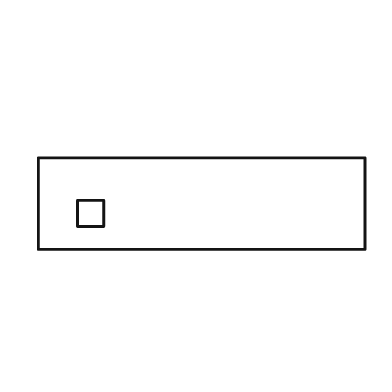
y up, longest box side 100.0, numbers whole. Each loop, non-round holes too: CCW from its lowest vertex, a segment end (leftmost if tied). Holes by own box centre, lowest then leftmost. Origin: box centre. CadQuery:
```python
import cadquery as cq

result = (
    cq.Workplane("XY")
    .moveTo(-50.0, -14.0)
    .lineTo(50.0, -14.0)
    .lineTo(50.0, 14.0)
    .lineTo(-50.0, 14.0)
    .close()
    .moveTo(-38.0, -7.0)
    .lineTo(-30.0, -7.0)
    .lineTo(-30.0, 1.0)
    .lineTo(-38.0, 1.0)
    .close()
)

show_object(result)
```